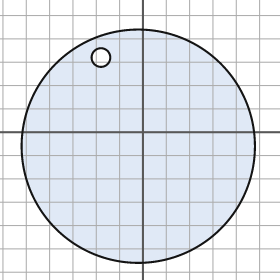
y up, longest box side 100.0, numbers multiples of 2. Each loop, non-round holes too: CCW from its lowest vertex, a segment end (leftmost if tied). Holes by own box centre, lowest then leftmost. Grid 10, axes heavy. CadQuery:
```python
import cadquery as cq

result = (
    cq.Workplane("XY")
    .moveTo(-2.0, -6.0)
    .circle(50.0)
    .moveTo(-18.0, 32.0)
    .circle(4.0)
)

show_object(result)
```